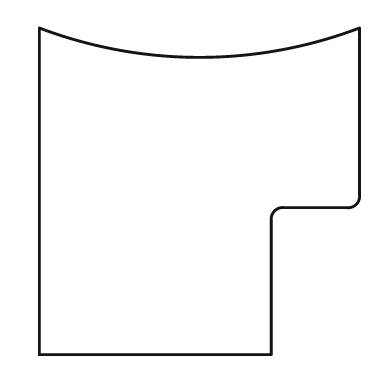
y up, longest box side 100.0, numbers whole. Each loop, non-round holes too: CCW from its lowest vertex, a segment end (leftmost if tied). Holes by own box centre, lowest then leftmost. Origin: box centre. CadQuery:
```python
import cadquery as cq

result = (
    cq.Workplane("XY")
    .moveTo(-49.0, -50.0)
    .lineTo(22.0, -50.0)
    .lineTo(22.0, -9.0)
    .threePointArc((23.0, -6.0), (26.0, -5.0))
    .lineTo(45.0, -5.0)
    .threePointArc((48.0, -4.0), (49.0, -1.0))
    .lineTo(49.0, 50.0)
    .threePointArc((0.0, 41.0), (-49.0, 50.0))
    .close()
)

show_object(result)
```